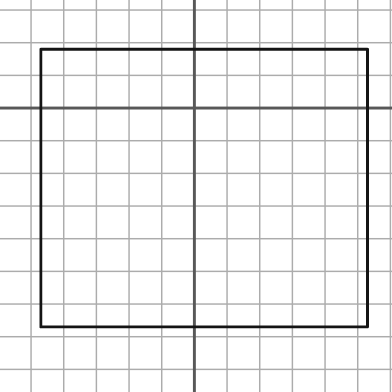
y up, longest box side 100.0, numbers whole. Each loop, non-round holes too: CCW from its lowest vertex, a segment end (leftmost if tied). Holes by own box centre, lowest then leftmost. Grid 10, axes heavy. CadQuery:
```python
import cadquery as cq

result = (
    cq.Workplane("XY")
    .moveTo(-47.0, -67.0)
    .lineTo(53.0, -67.0)
    .lineTo(53.0, 18.0)
    .lineTo(-47.0, 18.0)
    .close()
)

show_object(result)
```